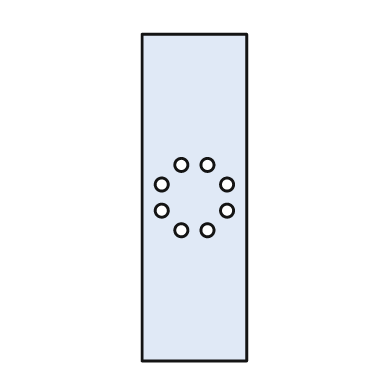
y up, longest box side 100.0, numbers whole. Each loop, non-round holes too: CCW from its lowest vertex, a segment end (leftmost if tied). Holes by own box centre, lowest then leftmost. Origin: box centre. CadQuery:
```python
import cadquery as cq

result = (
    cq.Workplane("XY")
    .moveTo(-16.0, -50.0)
    .lineTo(16.0, -50.0)
    .lineTo(16.0, 50.0)
    .lineTo(-16.0, 50.0)
    .close()
    .moveTo(-4.0, -10.0)
    .circle(2.0)
    .moveTo(4.0, -10.0)
    .circle(2.0)
    .moveTo(-10.0, -4.0)
    .circle(2.0)
    .moveTo(10.0, -4.0)
    .circle(2.0)
    .moveTo(-10.0, 4.0)
    .circle(2.0)
    .moveTo(10.0, 4.0)
    .circle(2.0)
    .moveTo(-4.0, 10.0)
    .circle(2.0)
    .moveTo(4.0, 10.0)
    .circle(2.0)
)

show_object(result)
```